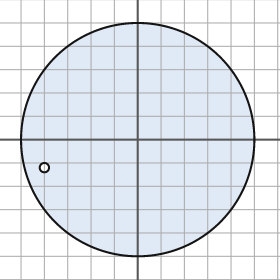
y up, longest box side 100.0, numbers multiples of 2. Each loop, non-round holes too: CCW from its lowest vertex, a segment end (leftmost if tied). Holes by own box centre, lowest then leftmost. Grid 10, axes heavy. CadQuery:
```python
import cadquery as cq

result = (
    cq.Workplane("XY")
    .moveTo(0.0, 0.0)
    .circle(50.0)
    .moveTo(-40.0, -12.0)
    .circle(2.0)
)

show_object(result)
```